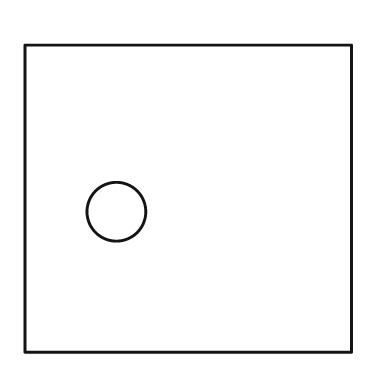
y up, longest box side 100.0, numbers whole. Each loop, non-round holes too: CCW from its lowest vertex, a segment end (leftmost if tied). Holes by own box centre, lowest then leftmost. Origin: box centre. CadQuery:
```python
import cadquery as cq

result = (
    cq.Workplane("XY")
    .moveTo(-50.0, -47.0)
    .lineTo(50.0, -47.0)
    .lineTo(50.0, 47.0)
    .lineTo(-50.0, 47.0)
    .close()
    .moveTo(-22.0, -4.0)
    .circle(9.0)
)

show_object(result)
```